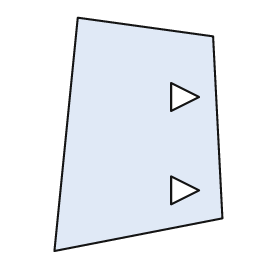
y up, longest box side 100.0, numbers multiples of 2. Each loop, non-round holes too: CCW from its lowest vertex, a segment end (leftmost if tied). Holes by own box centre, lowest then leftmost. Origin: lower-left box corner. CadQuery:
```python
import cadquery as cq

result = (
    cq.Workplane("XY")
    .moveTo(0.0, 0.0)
    .lineTo(72.0, 14.0)
    .lineTo(68.0, 92.0)
    .lineTo(10.0, 100.0)
    .close()
    .moveTo(50.0, 20.0)
    .lineTo(62.0, 26.0)
    .lineTo(50.0, 32.0)
    .close()
    .moveTo(50.0, 60.0)
    .lineTo(62.0, 66.0)
    .lineTo(50.0, 72.0)
    .close()
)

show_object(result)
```